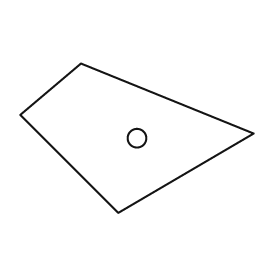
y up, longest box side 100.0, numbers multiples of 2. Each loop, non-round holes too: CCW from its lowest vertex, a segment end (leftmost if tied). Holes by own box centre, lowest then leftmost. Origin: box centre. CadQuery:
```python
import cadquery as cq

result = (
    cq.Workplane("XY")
    .moveTo(-8.0, -32.0)
    .lineTo(50.0, 2.0)
    .lineTo(-24.0, 32.0)
    .lineTo(-50.0, 10.0)
    .close()
    .moveTo(0.0, 0.0)
    .circle(4.0)
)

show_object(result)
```